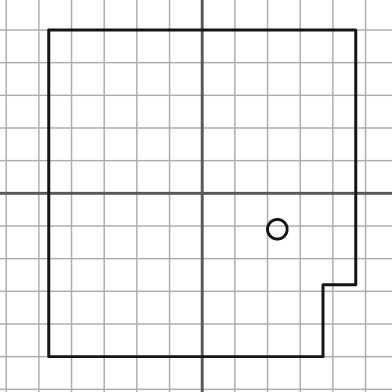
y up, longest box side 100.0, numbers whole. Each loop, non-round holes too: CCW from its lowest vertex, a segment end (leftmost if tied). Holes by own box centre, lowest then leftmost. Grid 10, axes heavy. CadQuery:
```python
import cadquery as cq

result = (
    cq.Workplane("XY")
    .moveTo(-47.0, -50.0)
    .lineTo(37.0, -50.0)
    .lineTo(37.0, -28.0)
    .lineTo(47.0, -28.0)
    .lineTo(47.0, 50.0)
    .lineTo(-47.0, 50.0)
    .close()
    .moveTo(23.0, -11.0)
    .circle(3.0)
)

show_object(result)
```